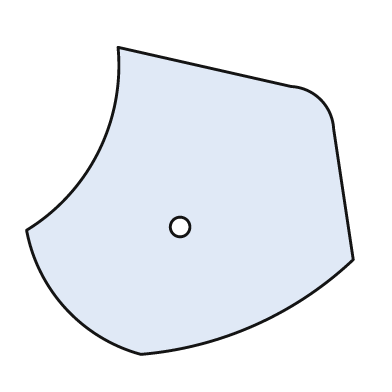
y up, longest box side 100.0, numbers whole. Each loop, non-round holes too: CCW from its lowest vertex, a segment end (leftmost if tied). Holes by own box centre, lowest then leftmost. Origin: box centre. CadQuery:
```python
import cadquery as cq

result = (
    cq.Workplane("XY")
    .moveTo(-15.0, -47.0)
    .threePointArc((20.0, -38.0), (50.0, -18.0))
    .lineTo(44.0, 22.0)
    .threePointArc((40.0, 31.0), (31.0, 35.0))
    .lineTo(-22.0, 47.0)
    .threePointArc((-28.0, 15.0), (-50.0, -9.0))
    .threePointArc((-38.0, -33.0), (-15.0, -47.0))
    .close()
    .moveTo(-3.0, -8.0)
    .circle(3.0)
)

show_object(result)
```